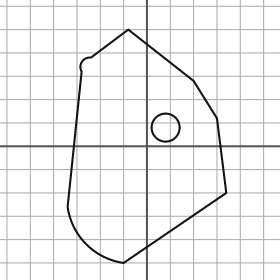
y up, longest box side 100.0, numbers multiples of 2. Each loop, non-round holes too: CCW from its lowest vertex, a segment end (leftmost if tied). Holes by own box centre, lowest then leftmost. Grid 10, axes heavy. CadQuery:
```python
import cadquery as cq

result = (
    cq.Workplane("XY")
    .moveTo(-10.0, -50.0)
    .lineTo(34.0, -20.0)
    .lineTo(30.0, 12.0)
    .lineTo(20.0, 28.0)
    .lineTo(-8.0, 50.0)
    .lineTo(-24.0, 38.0)
    .threePointArc((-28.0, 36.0), (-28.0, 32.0))
    .lineTo(-34.0, -26.0)
    .threePointArc((-26.0, -42.0), (-10.0, -50.0))
    .close()
    .moveTo(8.0, 8.0)
    .circle(6.0)
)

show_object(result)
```